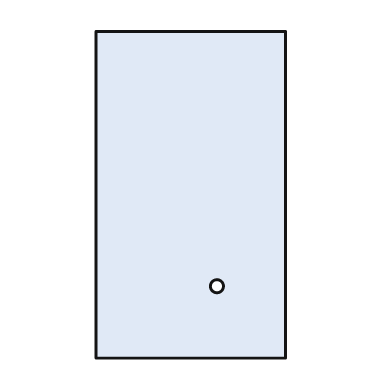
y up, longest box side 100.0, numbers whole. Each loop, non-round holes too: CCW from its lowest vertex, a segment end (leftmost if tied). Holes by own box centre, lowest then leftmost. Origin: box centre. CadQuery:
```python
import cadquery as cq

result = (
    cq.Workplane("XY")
    .moveTo(-29.0, -50.0)
    .lineTo(29.0, -50.0)
    .lineTo(29.0, 50.0)
    .lineTo(-29.0, 50.0)
    .close()
    .moveTo(8.0, -28.0)
    .circle(2.0)
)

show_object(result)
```